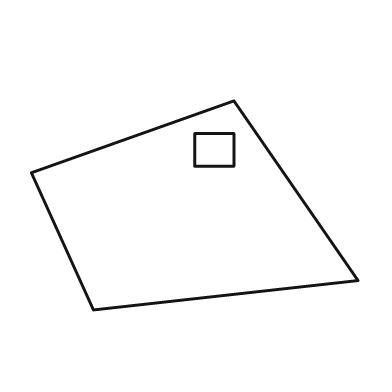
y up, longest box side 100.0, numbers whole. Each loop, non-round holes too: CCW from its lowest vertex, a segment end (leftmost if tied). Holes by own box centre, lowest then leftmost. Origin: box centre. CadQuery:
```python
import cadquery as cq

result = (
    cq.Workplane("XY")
    .moveTo(-31.0, -32.0)
    .lineTo(50.0, -23.0)
    .lineTo(12.0, 32.0)
    .lineTo(-50.0, 10.0)
    .close()
    .moveTo(0.0, 12.0)
    .lineTo(12.0, 12.0)
    .lineTo(12.0, 22.0)
    .lineTo(0.0, 22.0)
    .close()
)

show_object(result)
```